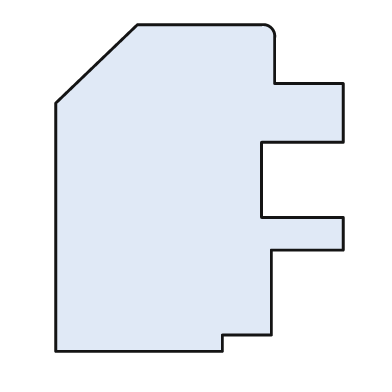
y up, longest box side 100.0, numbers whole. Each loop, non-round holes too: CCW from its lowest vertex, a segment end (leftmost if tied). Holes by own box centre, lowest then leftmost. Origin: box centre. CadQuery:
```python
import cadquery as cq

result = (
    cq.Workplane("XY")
    .moveTo(-44.0, -50.0)
    .lineTo(7.0, -50.0)
    .lineTo(7.0, -45.0)
    .lineTo(22.0, -45.0)
    .lineTo(22.0, -19.0)
    .lineTo(44.0, -19.0)
    .lineTo(44.0, -9.0)
    .lineTo(19.0, -9.0)
    .lineTo(19.0, 14.0)
    .lineTo(44.0, 14.0)
    .lineTo(44.0, 32.0)
    .lineTo(23.0, 32.0)
    .lineTo(23.0, 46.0)
    .threePointArc((22.0, 49.0), (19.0, 50.0))
    .lineTo(-19.0, 50.0)
    .lineTo(-44.0, 26.0)
    .close()
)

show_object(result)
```